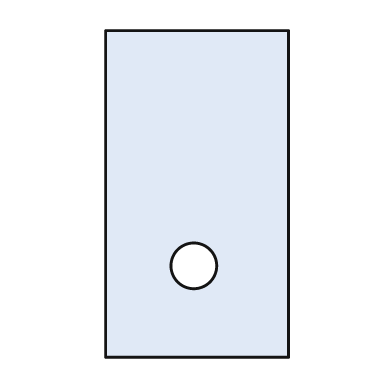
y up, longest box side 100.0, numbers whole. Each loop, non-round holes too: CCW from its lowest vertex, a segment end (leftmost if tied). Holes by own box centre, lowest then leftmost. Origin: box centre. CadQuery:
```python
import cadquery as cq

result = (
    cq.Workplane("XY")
    .moveTo(-28.0, -50.0)
    .lineTo(28.0, -50.0)
    .lineTo(28.0, 50.0)
    .lineTo(-28.0, 50.0)
    .close()
    .moveTo(-1.0, -22.0)
    .circle(7.0)
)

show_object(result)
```